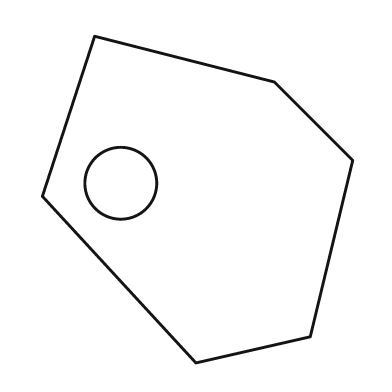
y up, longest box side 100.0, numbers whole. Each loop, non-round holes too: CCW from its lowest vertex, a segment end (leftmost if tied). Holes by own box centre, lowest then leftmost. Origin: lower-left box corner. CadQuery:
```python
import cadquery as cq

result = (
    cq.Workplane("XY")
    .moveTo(47.0, 0.0)
    .lineTo(82.0, 8.0)
    .lineTo(95.0, 62.0)
    .lineTo(71.0, 86.0)
    .lineTo(16.0, 100.0)
    .lineTo(0.0, 51.0)
    .close()
    .moveTo(24.0, 55.0)
    .circle(11.0)
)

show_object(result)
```